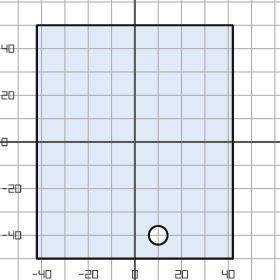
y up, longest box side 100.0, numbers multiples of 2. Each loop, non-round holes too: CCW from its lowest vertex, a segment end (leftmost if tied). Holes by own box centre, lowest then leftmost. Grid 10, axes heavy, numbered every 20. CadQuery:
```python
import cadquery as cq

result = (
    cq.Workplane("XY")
    .moveTo(-42.0, -50.0)
    .lineTo(42.0, -50.0)
    .lineTo(42.0, 50.0)
    .lineTo(-42.0, 50.0)
    .close()
    .moveTo(10.0, -40.0)
    .circle(4.0)
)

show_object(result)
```